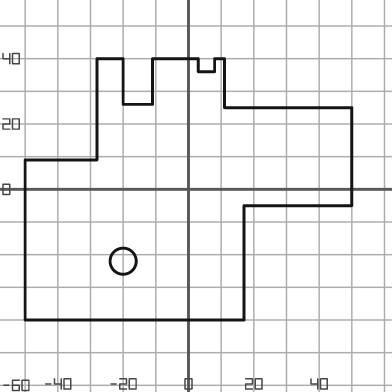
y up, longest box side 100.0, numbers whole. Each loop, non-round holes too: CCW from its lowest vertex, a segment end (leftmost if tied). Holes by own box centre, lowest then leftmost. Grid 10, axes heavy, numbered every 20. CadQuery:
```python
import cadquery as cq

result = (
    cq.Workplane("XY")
    .moveTo(-50.0, -40.0)
    .lineTo(17.0, -40.0)
    .lineTo(17.0, -5.0)
    .lineTo(50.0, -5.0)
    .lineTo(50.0, 25.0)
    .lineTo(11.0, 25.0)
    .lineTo(11.0, 40.0)
    .lineTo(8.0, 40.0)
    .lineTo(8.0, 36.0)
    .lineTo(3.0, 36.0)
    .lineTo(3.0, 40.0)
    .lineTo(-11.0, 40.0)
    .lineTo(-11.0, 26.0)
    .lineTo(-20.0, 26.0)
    .lineTo(-20.0, 40.0)
    .lineTo(-28.0, 40.0)
    .lineTo(-28.0, 9.0)
    .lineTo(-50.0, 9.0)
    .close()
    .moveTo(-20.0, -22.0)
    .circle(4.0)
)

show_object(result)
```